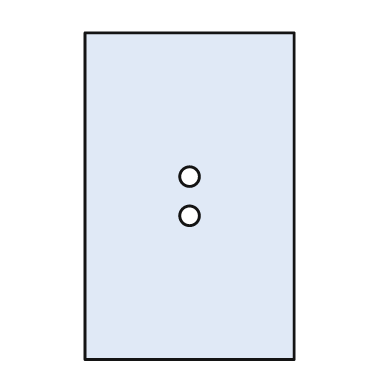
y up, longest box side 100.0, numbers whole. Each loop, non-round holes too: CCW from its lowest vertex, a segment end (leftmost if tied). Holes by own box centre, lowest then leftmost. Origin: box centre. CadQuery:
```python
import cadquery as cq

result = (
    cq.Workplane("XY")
    .moveTo(-32.0, -50.0)
    .lineTo(32.0, -50.0)
    .lineTo(32.0, 50.0)
    .lineTo(-32.0, 50.0)
    .close()
    .moveTo(0.0, -6.0)
    .circle(3.0)
    .moveTo(0.0, 6.0)
    .circle(3.0)
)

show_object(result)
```